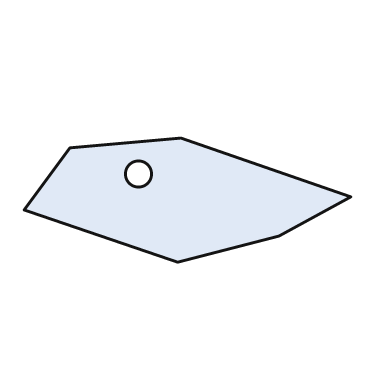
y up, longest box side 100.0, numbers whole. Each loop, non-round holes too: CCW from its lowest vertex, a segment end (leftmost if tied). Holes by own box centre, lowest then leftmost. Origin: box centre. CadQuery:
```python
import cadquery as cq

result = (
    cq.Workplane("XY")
    .moveTo(-3.0, -19.0)
    .lineTo(28.0, -11.0)
    .lineTo(50.0, 1.0)
    .lineTo(-2.0, 19.0)
    .lineTo(-36.0, 16.0)
    .lineTo(-50.0, -3.0)
    .close()
    .moveTo(-15.0, 8.0)
    .circle(4.0)
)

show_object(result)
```